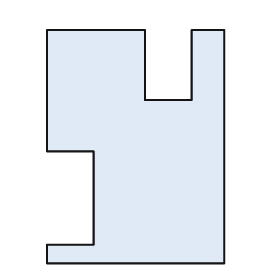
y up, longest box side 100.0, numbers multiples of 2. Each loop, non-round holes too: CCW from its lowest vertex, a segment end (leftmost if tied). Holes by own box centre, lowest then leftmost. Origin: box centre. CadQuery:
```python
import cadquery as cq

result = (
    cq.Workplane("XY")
    .moveTo(-38.0, -50.0)
    .lineTo(38.0, -50.0)
    .lineTo(38.0, 50.0)
    .lineTo(24.0, 50.0)
    .lineTo(24.0, 20.0)
    .lineTo(4.0, 20.0)
    .lineTo(4.0, 50.0)
    .lineTo(-38.0, 50.0)
    .lineTo(-38.0, -2.0)
    .lineTo(-18.0, -2.0)
    .lineTo(-18.0, -42.0)
    .lineTo(-38.0, -42.0)
    .close()
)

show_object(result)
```